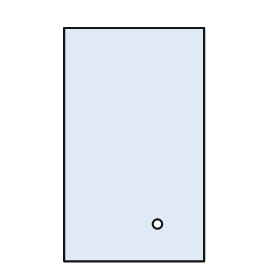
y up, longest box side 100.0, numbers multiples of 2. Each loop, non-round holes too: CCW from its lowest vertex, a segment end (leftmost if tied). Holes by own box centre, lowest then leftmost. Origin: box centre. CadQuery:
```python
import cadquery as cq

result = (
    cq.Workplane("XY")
    .moveTo(-30.0, -50.0)
    .lineTo(30.0, -50.0)
    .lineTo(30.0, 50.0)
    .lineTo(-30.0, 50.0)
    .close()
    .moveTo(10.0, -34.0)
    .circle(2.0)
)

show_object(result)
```